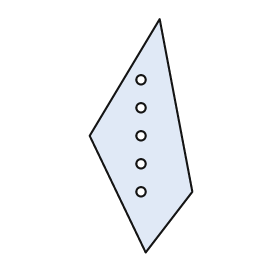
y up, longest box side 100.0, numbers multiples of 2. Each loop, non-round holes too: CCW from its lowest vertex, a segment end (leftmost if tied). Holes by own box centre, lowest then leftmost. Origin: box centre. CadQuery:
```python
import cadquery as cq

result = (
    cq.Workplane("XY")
    .moveTo(2.0, -50.0)
    .lineTo(22.0, -24.0)
    .lineTo(8.0, 50.0)
    .lineTo(-22.0, 0.0)
    .close()
    .moveTo(0.0, -24.0)
    .circle(2.0)
    .moveTo(0.0, -12.0)
    .circle(2.0)
    .moveTo(0.0, 0.0)
    .circle(2.0)
    .moveTo(0.0, 12.0)
    .circle(2.0)
    .moveTo(0.0, 24.0)
    .circle(2.0)
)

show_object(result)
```